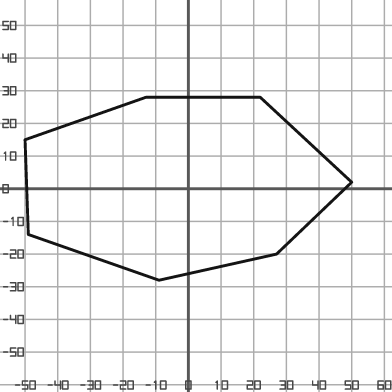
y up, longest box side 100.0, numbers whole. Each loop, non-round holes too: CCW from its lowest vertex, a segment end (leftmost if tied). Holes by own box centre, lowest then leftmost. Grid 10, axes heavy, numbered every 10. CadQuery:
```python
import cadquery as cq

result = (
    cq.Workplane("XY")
    .moveTo(-9.0, -28.0)
    .lineTo(27.0, -20.0)
    .lineTo(50.0, 2.0)
    .lineTo(22.0, 28.0)
    .lineTo(-13.0, 28.0)
    .lineTo(-50.0, 15.0)
    .lineTo(-49.0, -14.0)
    .close()
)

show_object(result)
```